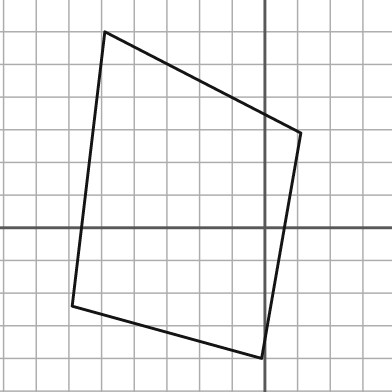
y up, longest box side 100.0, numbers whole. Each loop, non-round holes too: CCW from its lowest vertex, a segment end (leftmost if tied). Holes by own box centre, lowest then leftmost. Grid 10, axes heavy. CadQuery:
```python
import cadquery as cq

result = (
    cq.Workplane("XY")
    .moveTo(-1.0, -40.0)
    .lineTo(11.0, 29.0)
    .lineTo(-49.0, 60.0)
    .lineTo(-59.0, -24.0)
    .close()
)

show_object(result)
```